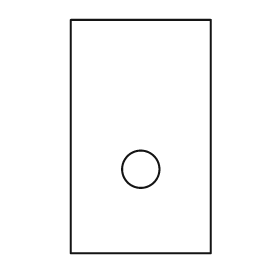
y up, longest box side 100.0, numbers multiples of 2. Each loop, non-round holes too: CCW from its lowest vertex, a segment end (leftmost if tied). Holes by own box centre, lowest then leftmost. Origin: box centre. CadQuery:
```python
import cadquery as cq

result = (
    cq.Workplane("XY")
    .moveTo(-30.0, -50.0)
    .lineTo(30.0, -50.0)
    .lineTo(30.0, 50.0)
    .lineTo(-30.0, 50.0)
    .close()
    .moveTo(0.0, -14.0)
    .circle(8.0)
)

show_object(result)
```